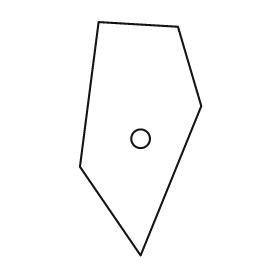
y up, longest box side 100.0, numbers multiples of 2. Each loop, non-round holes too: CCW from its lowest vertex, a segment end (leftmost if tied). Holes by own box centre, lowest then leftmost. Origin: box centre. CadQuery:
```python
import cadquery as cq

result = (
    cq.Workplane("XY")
    .moveTo(0.0, -50.0)
    .lineTo(26.0, 14.0)
    .lineTo(16.0, 48.0)
    .lineTo(-18.0, 50.0)
    .lineTo(-26.0, -12.0)
    .close()
    .moveTo(0.0, 0.0)
    .circle(4.0)
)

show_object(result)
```